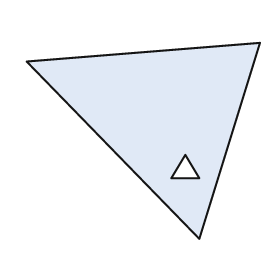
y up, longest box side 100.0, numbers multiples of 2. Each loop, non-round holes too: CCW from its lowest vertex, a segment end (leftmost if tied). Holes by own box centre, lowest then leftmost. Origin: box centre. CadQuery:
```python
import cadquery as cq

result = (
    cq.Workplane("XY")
    .moveTo(24.0, -42.0)
    .lineTo(50.0, 42.0)
    .lineTo(-50.0, 34.0)
    .close()
    .moveTo(12.0, -16.0)
    .lineTo(24.0, -16.0)
    .lineTo(18.0, -6.0)
    .close()
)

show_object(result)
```